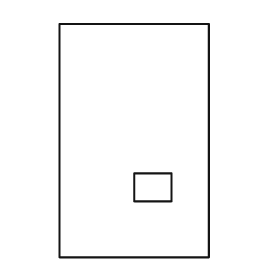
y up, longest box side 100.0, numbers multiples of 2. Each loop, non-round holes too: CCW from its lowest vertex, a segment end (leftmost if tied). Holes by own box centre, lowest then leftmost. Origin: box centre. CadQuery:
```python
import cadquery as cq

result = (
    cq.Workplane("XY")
    .moveTo(-32.0, -50.0)
    .lineTo(32.0, -50.0)
    .lineTo(32.0, 50.0)
    .lineTo(-32.0, 50.0)
    .close()
    .moveTo(0.0, -26.0)
    .lineTo(16.0, -26.0)
    .lineTo(16.0, -14.0)
    .lineTo(0.0, -14.0)
    .close()
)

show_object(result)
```